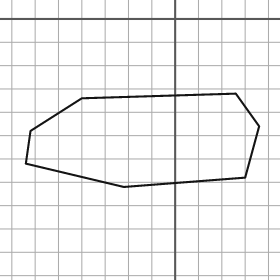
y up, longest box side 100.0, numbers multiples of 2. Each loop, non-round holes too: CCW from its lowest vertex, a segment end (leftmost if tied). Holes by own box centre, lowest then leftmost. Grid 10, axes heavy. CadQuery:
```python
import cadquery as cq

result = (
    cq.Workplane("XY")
    .moveTo(-22.0, -72.0)
    .lineTo(30.0, -68.0)
    .lineTo(36.0, -46.0)
    .lineTo(26.0, -32.0)
    .lineTo(-40.0, -34.0)
    .lineTo(-62.0, -48.0)
    .lineTo(-64.0, -62.0)
    .close()
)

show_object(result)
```